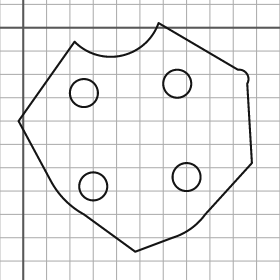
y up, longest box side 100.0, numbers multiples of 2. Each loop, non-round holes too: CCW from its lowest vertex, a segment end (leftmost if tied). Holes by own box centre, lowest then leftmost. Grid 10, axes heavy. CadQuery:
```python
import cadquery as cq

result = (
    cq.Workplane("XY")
    .moveTo(48.0, -96.0)
    .lineTo(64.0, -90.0)
    .threePointArc((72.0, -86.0), (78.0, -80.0))
    .lineTo(98.0, -58.0)
    .lineTo(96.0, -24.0)
    .threePointArc((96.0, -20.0), (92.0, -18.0))
    .lineTo(58.0, 2.0)
    .threePointArc((42.0, -12.0), (22.0, -6.0))
    .lineTo(-2.0, -40.0)
    .lineTo(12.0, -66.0)
    .threePointArc((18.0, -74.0), (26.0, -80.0))
    .close()
    .moveTo(30.0, -68.0)
    .circle(6.0)
    .moveTo(70.0, -64.0)
    .circle(6.0)
    .moveTo(26.0, -28.0)
    .circle(6.0)
    .moveTo(66.0, -24.0)
    .circle(6.0)
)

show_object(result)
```